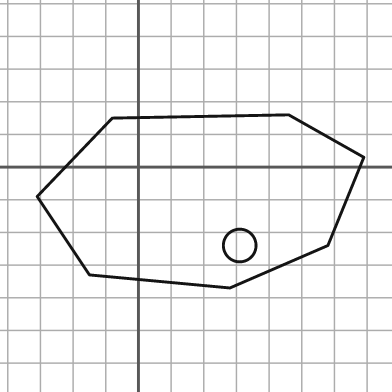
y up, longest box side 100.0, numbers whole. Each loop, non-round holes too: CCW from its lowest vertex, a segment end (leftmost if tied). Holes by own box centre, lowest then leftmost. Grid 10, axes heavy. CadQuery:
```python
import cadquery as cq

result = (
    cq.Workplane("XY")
    .moveTo(28.0, -37.0)
    .lineTo(58.0, -24.0)
    .lineTo(69.0, 3.0)
    .lineTo(46.0, 16.0)
    .lineTo(-8.0, 15.0)
    .lineTo(-31.0, -9.0)
    .lineTo(-15.0, -33.0)
    .close()
    .moveTo(31.0, -24.0)
    .circle(5.0)
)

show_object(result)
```